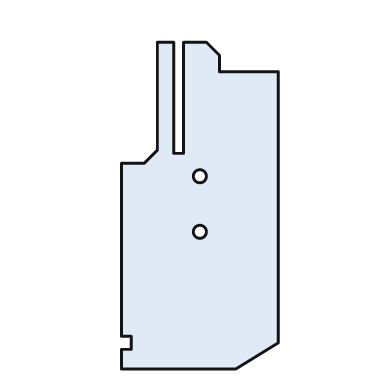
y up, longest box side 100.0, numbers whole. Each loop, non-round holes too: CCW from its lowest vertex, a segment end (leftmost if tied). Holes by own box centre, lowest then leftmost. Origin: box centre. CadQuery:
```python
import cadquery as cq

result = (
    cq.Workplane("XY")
    .moveTo(-24.0, -50.0)
    .lineTo(11.0, -50.0)
    .lineTo(24.0, -42.0)
    .lineTo(24.0, 41.0)
    .lineTo(6.0, 41.0)
    .lineTo(6.0, 46.0)
    .lineTo(2.0, 50.0)
    .lineTo(-5.0, 50.0)
    .lineTo(-5.0, 16.0)
    .lineTo(-8.0, 16.0)
    .lineTo(-8.0, 50.0)
    .lineTo(-13.0, 50.0)
    .lineTo(-13.0, 17.0)
    .lineTo(-17.0, 13.0)
    .lineTo(-24.0, 13.0)
    .lineTo(-24.0, -40.0)
    .lineTo(-21.0, -40.0)
    .lineTo(-21.0, -44.0)
    .lineTo(-24.0, -44.0)
    .close()
    .moveTo(0.0, -8.0)
    .circle(2.0)
    .moveTo(0.0, 9.0)
    .circle(2.0)
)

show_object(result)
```